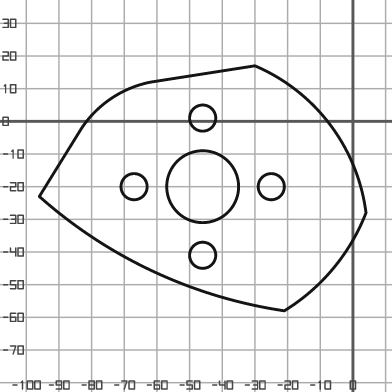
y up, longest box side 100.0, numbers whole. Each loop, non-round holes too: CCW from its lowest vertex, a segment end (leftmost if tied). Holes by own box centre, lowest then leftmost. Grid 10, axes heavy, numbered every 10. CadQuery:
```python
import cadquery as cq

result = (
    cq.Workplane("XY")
    .moveTo(-21.0, -58.0)
    .threePointArc((-6.0, -45.0), (4.0, -28.0))
    .threePointArc((-7.0, -1.0), (-30.0, 17.0))
    .lineTo(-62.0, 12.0)
    .threePointArc((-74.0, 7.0), (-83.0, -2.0))
    .lineTo(-96.0, -23.0)
    .threePointArc((-61.0, -46.0), (-21.0, -58.0))
    .close()
    .moveTo(-46.0, -41.0)
    .circle(4.0)
    .moveTo(-67.0, -20.0)
    .circle(4.0)
    .moveTo(-46.0, -20.0)
    .circle(11.0)
    .moveTo(-25.0, -20.0)
    .circle(4.0)
    .moveTo(-46.0, 1.0)
    .circle(4.0)
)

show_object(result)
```